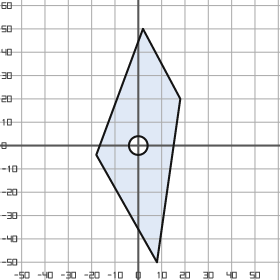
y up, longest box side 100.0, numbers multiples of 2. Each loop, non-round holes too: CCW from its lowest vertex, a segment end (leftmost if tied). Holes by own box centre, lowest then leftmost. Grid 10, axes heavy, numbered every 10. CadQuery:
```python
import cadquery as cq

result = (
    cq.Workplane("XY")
    .moveTo(8.0, -50.0)
    .lineTo(18.0, 20.0)
    .lineTo(2.0, 50.0)
    .lineTo(-18.0, -4.0)
    .close()
    .moveTo(0.0, 0.0)
    .circle(4.0)
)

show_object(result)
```